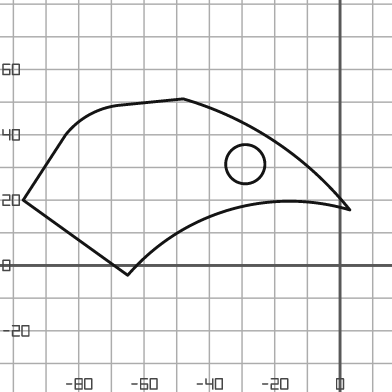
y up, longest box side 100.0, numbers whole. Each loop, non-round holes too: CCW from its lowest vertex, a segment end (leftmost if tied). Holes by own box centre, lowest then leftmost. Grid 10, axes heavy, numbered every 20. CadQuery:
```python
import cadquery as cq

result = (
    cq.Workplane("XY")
    .moveTo(-65.0, -3.0)
    .threePointArc((-34.0, 17.0), (3.0, 17.0))
    .threePointArc((-20.0, 38.0), (-48.0, 51.0))
    .lineTo(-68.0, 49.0)
    .threePointArc((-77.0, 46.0), (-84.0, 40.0))
    .lineTo(-97.0, 20.0)
    .close()
    .moveTo(-29.0, 31.0)
    .circle(6.0)
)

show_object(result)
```